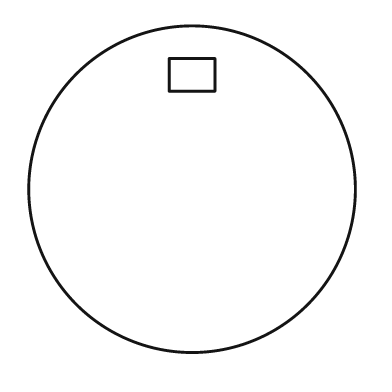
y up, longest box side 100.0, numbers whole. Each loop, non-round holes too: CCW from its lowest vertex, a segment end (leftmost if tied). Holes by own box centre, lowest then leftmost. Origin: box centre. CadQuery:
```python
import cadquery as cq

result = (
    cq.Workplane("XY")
    .moveTo(0.0, 0.0)
    .circle(50.0)
    .moveTo(-7.0, 30.0)
    .lineTo(7.0, 30.0)
    .lineTo(7.0, 40.0)
    .lineTo(-7.0, 40.0)
    .close()
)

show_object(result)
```